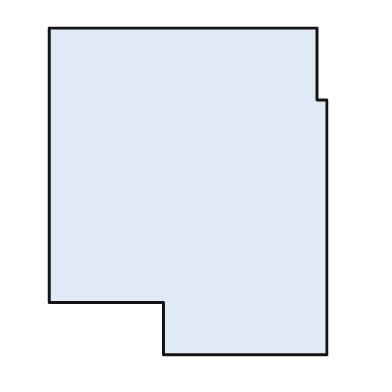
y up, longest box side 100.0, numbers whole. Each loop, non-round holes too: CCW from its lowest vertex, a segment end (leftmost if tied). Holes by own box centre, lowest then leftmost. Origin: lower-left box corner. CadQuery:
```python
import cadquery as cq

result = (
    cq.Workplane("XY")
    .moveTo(35.0, 0.0)
    .lineTo(85.0, 0.0)
    .lineTo(85.0, 78.0)
    .lineTo(82.0, 78.0)
    .lineTo(82.0, 100.0)
    .lineTo(0.0, 100.0)
    .lineTo(0.0, 16.0)
    .lineTo(35.0, 16.0)
    .close()
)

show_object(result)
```